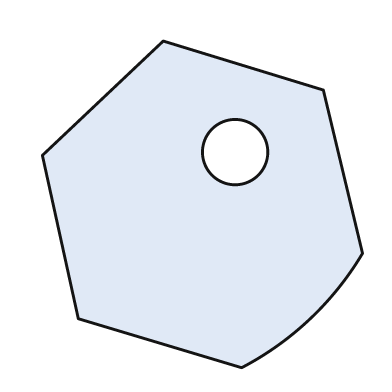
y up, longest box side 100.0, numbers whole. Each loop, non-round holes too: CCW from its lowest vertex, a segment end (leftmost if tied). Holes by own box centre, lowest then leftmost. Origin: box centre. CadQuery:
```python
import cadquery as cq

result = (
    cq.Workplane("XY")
    .moveTo(12.0, -50.0)
    .threePointArc((33.0, -35.0), (49.0, -15.0))
    .lineTo(37.0, 35.0)
    .lineTo(-12.0, 50.0)
    .lineTo(-49.0, 15.0)
    .lineTo(-38.0, -35.0)
    .close()
    .moveTo(10.0, 16.0)
    .circle(10.0)
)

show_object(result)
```